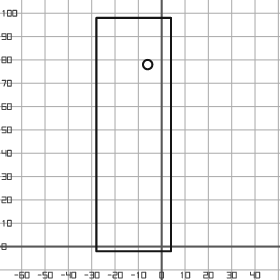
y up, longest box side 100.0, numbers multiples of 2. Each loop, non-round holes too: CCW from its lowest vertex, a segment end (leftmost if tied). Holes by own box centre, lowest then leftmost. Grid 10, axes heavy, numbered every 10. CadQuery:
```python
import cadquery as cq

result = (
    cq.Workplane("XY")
    .moveTo(-28.0, -2.0)
    .lineTo(4.0, -2.0)
    .lineTo(4.0, 98.0)
    .lineTo(-28.0, 98.0)
    .close()
    .moveTo(-6.0, 78.0)
    .circle(2.0)
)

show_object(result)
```